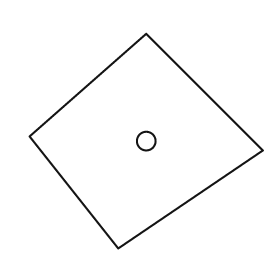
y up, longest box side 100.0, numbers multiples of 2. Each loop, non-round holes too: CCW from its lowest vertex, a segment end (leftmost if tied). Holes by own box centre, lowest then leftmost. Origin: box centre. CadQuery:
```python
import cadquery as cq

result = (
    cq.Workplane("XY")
    .moveTo(-12.0, -46.0)
    .lineTo(50.0, -4.0)
    .lineTo(0.0, 46.0)
    .lineTo(-50.0, 2.0)
    .close()
    .moveTo(0.0, 0.0)
    .circle(4.0)
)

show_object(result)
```